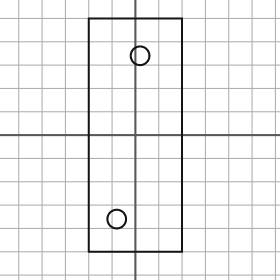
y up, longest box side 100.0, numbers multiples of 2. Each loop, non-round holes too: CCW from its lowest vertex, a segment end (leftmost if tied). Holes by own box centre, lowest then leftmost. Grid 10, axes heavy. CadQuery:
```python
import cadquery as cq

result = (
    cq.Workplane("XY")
    .moveTo(-20.0, -50.0)
    .lineTo(20.0, -50.0)
    .lineTo(20.0, 50.0)
    .lineTo(-20.0, 50.0)
    .close()
    .moveTo(-8.0, -36.0)
    .circle(4.0)
    .moveTo(2.0, 34.0)
    .circle(4.0)
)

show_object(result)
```